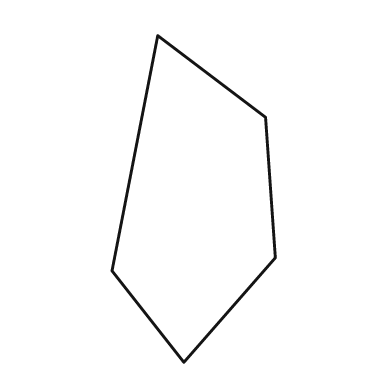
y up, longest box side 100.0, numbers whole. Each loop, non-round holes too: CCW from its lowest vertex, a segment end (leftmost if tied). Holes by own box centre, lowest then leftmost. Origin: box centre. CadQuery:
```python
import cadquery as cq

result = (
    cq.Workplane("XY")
    .moveTo(-3.0, -50.0)
    .lineTo(25.0, -18.0)
    .lineTo(22.0, 25.0)
    .lineTo(-11.0, 50.0)
    .lineTo(-25.0, -22.0)
    .close()
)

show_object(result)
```